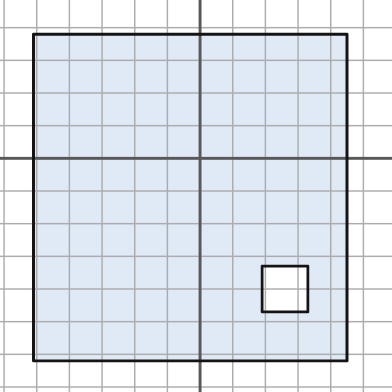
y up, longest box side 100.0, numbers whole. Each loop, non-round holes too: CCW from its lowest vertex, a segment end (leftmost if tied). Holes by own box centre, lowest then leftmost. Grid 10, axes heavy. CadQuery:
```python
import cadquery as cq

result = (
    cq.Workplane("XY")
    .moveTo(-51.0, -62.0)
    .lineTo(45.0, -62.0)
    .lineTo(45.0, 38.0)
    .lineTo(-51.0, 38.0)
    .close()
    .moveTo(19.0, -47.0)
    .lineTo(33.0, -47.0)
    .lineTo(33.0, -33.0)
    .lineTo(19.0, -33.0)
    .close()
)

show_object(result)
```